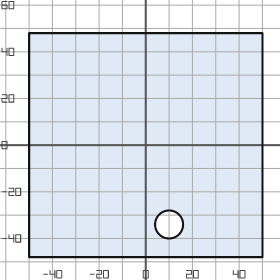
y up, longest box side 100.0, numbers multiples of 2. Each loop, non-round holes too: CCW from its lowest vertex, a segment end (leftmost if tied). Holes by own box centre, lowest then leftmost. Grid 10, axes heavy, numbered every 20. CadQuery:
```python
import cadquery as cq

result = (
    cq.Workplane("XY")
    .moveTo(-50.0, -48.0)
    .lineTo(50.0, -48.0)
    .lineTo(50.0, 48.0)
    .lineTo(-50.0, 48.0)
    .close()
    .moveTo(10.0, -34.0)
    .circle(6.0)
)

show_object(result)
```